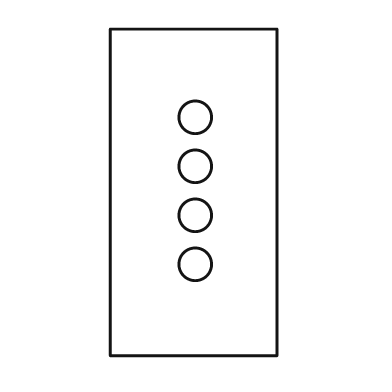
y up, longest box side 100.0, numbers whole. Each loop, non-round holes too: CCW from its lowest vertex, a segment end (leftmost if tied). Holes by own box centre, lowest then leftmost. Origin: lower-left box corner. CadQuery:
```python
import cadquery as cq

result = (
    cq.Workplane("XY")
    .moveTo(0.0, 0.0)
    .lineTo(51.0, 0.0)
    .lineTo(51.0, 100.0)
    .lineTo(0.0, 100.0)
    .close()
    .moveTo(26.0, 28.0)
    .circle(5.0)
    .moveTo(26.0, 43.0)
    .circle(5.0)
    .moveTo(26.0, 58.0)
    .circle(5.0)
    .moveTo(26.0, 73.0)
    .circle(5.0)
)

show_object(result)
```